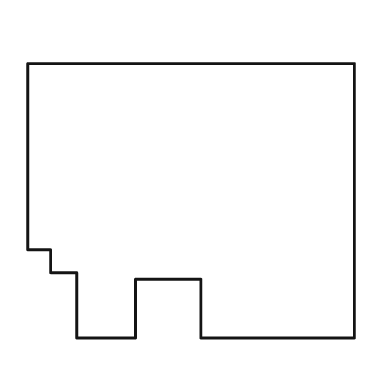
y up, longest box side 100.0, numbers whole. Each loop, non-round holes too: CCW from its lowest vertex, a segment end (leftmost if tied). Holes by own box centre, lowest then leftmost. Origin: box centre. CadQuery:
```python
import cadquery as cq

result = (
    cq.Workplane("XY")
    .moveTo(-35.0, -42.0)
    .lineTo(-17.0, -42.0)
    .lineTo(-17.0, -24.0)
    .lineTo(3.0, -24.0)
    .lineTo(3.0, -42.0)
    .lineTo(50.0, -42.0)
    .lineTo(50.0, 42.0)
    .lineTo(-50.0, 42.0)
    .lineTo(-50.0, -15.0)
    .lineTo(-43.0, -15.0)
    .lineTo(-43.0, -22.0)
    .lineTo(-35.0, -22.0)
    .close()
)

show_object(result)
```